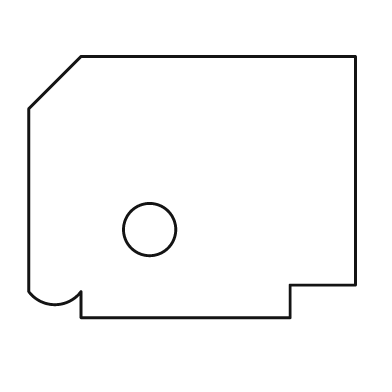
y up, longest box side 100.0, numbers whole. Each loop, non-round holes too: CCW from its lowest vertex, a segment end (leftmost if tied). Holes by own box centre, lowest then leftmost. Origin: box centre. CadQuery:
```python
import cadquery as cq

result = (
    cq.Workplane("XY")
    .moveTo(-34.0, -40.0)
    .lineTo(30.0, -40.0)
    .lineTo(30.0, -30.0)
    .lineTo(50.0, -30.0)
    .lineTo(50.0, 40.0)
    .lineTo(-34.0, 40.0)
    .lineTo(-50.0, 24.0)
    .lineTo(-50.0, -32.0)
    .threePointArc((-42.0, -36.0), (-34.0, -32.0))
    .close()
    .moveTo(-13.0, -13.0)
    .circle(8.0)
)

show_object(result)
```